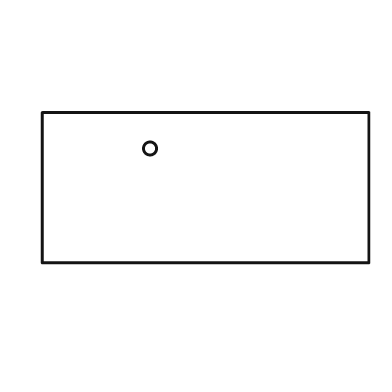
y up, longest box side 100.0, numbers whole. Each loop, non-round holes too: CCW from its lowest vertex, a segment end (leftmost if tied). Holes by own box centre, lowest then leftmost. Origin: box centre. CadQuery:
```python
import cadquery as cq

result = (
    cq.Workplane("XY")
    .moveTo(-50.0, -23.0)
    .lineTo(50.0, -23.0)
    .lineTo(50.0, 23.0)
    .lineTo(-50.0, 23.0)
    .close()
    .moveTo(-17.0, 12.0)
    .circle(2.0)
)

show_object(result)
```